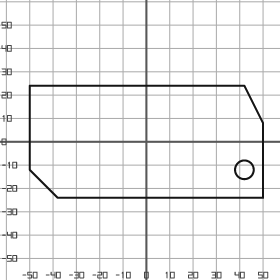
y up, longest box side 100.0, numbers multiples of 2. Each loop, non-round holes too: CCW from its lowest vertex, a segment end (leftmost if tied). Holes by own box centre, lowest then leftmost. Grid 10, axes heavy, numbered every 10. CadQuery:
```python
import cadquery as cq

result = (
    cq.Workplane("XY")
    .moveTo(-38.0, -24.0)
    .lineTo(50.0, -24.0)
    .lineTo(50.0, 8.0)
    .lineTo(42.0, 24.0)
    .lineTo(-50.0, 24.0)
    .lineTo(-50.0, -12.0)
    .close()
    .moveTo(42.0, -12.0)
    .circle(4.0)
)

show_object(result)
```